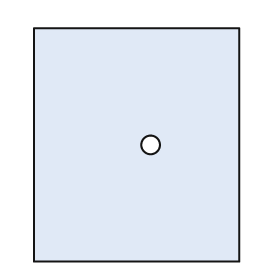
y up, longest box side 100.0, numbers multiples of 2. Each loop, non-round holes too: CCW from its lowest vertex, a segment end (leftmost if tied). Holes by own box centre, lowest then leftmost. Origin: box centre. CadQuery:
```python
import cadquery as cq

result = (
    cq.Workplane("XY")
    .moveTo(-44.0, -50.0)
    .lineTo(44.0, -50.0)
    .lineTo(44.0, 50.0)
    .lineTo(-44.0, 50.0)
    .close()
    .moveTo(6.0, 0.0)
    .circle(4.0)
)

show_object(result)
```